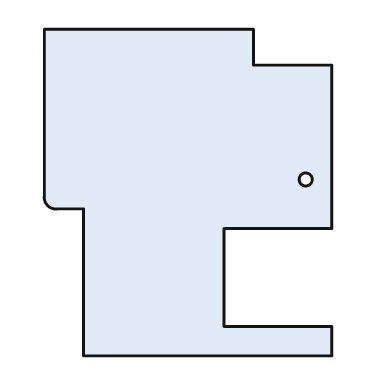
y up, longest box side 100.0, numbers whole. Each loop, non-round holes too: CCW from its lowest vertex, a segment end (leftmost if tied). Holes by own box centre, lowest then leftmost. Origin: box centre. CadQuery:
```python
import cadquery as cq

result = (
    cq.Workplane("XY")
    .moveTo(-32.0, -50.0)
    .lineTo(44.0, -50.0)
    .lineTo(44.0, -41.0)
    .lineTo(11.0, -41.0)
    .lineTo(11.0, -11.0)
    .lineTo(44.0, -11.0)
    .lineTo(44.0, 39.0)
    .lineTo(20.0, 39.0)
    .lineTo(20.0, 50.0)
    .lineTo(-44.0, 50.0)
    .lineTo(-44.0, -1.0)
    .threePointArc((-43.0, -4.0), (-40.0, -5.0))
    .lineTo(-32.0, -5.0)
    .close()
    .moveTo(36.0, 4.0)
    .circle(2.0)
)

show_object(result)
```